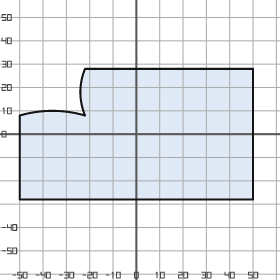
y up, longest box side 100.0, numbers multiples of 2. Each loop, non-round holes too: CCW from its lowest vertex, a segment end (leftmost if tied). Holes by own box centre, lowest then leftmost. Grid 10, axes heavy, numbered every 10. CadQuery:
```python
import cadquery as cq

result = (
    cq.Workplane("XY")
    .moveTo(-50.0, -28.0)
    .lineTo(50.0, -28.0)
    .lineTo(50.0, 28.0)
    .lineTo(-22.0, 28.0)
    .threePointArc((-24.0, 18.0), (-22.0, 8.0))
    .threePointArc((-36.0, 10.0), (-50.0, 8.0))
    .close()
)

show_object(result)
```